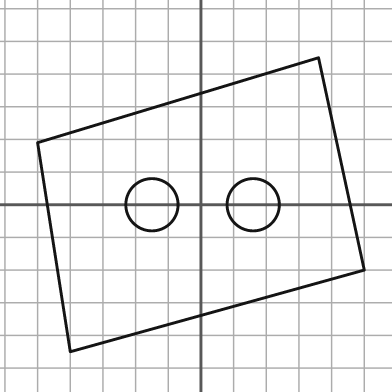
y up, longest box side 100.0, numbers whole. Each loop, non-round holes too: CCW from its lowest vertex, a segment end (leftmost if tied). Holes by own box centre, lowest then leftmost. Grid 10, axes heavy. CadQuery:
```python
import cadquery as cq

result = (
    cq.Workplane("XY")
    .moveTo(-40.0, -45.0)
    .lineTo(50.0, -20.0)
    .lineTo(36.0, 45.0)
    .lineTo(-50.0, 19.0)
    .close()
    .moveTo(-15.0, 0.0)
    .circle(8.0)
    .moveTo(16.0, 0.0)
    .circle(8.0)
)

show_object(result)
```